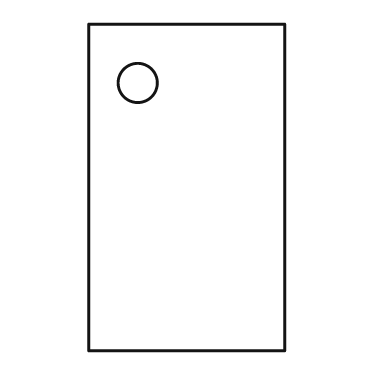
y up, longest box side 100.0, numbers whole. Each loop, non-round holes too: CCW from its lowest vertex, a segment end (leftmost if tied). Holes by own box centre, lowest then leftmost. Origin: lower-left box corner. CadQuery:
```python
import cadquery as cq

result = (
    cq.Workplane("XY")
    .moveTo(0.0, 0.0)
    .lineTo(60.0, 0.0)
    .lineTo(60.0, 100.0)
    .lineTo(0.0, 100.0)
    .close()
    .moveTo(15.0, 82.0)
    .circle(6.0)
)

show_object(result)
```